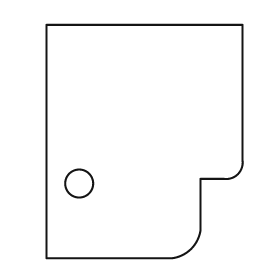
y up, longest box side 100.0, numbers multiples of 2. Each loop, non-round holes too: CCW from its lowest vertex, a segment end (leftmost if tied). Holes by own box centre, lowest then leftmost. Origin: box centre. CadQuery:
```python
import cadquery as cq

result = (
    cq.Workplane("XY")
    .moveTo(-42.0, -50.0)
    .lineTo(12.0, -50.0)
    .threePointArc((20.0, -46.0), (24.0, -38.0))
    .lineTo(24.0, -16.0)
    .lineTo(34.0, -16.0)
    .threePointArc((40.0, -14.0), (42.0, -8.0))
    .lineTo(42.0, 50.0)
    .lineTo(-42.0, 50.0)
    .close()
    .moveTo(-28.0, -18.0)
    .circle(6.0)
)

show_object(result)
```